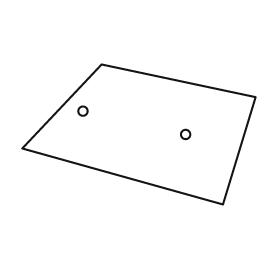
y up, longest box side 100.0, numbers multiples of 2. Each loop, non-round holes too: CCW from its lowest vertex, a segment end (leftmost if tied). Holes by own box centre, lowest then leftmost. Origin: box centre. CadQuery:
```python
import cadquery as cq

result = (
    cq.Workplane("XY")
    .moveTo(36.0, -30.0)
    .lineTo(50.0, 16.0)
    .lineTo(-16.0, 30.0)
    .lineTo(-50.0, -6.0)
    .close()
    .moveTo(20.0, 0.0)
    .circle(2.0)
    .moveTo(-24.0, 10.0)
    .circle(2.0)
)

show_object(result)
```